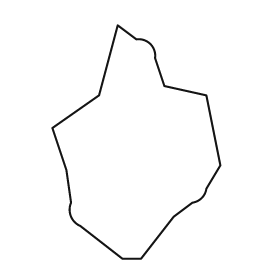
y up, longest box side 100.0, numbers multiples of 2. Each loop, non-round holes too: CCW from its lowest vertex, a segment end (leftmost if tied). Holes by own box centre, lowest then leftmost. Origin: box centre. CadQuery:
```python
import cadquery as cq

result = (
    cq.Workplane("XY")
    .moveTo(-6.0, -50.0)
    .lineTo(2.0, -50.0)
    .lineTo(16.0, -32.0)
    .lineTo(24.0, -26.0)
    .threePointArc((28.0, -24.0), (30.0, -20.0))
    .lineTo(36.0, -10.0)
    .lineTo(30.0, 20.0)
    .lineTo(12.0, 24.0)
    .lineTo(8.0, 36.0)
    .threePointArc((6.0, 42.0), (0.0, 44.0))
    .lineTo(-8.0, 50.0)
    .lineTo(-16.0, 20.0)
    .lineTo(-36.0, 6.0)
    .lineTo(-30.0, -12.0)
    .lineTo(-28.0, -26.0)
    .threePointArc((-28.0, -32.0), (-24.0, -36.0))
    .close()
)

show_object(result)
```